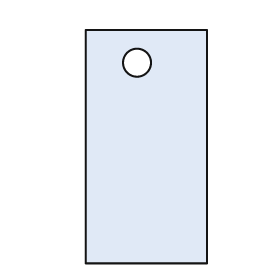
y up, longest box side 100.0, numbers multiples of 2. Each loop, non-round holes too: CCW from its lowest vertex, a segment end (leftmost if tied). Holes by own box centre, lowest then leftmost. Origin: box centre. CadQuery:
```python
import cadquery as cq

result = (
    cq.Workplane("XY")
    .moveTo(-26.0, -50.0)
    .lineTo(26.0, -50.0)
    .lineTo(26.0, 50.0)
    .lineTo(-26.0, 50.0)
    .close()
    .moveTo(-4.0, 36.0)
    .circle(6.0)
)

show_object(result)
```